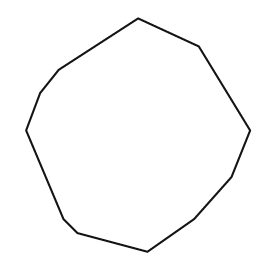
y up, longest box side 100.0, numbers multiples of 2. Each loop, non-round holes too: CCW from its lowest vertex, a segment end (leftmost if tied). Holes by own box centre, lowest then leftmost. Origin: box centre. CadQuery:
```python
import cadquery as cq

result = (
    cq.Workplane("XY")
    .moveTo(4.0, -50.0)
    .lineTo(24.0, -36.0)
    .lineTo(40.0, -18.0)
    .lineTo(48.0, 2.0)
    .lineTo(26.0, 38.0)
    .lineTo(0.0, 50.0)
    .lineTo(-34.0, 28.0)
    .lineTo(-42.0, 18.0)
    .lineTo(-48.0, 2.0)
    .lineTo(-32.0, -36.0)
    .lineTo(-26.0, -42.0)
    .close()
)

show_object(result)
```